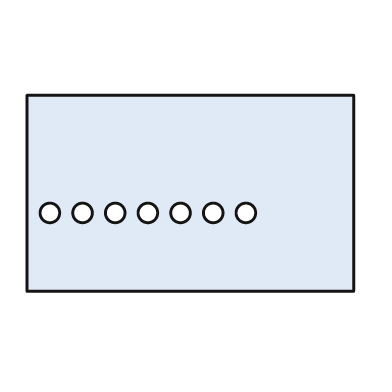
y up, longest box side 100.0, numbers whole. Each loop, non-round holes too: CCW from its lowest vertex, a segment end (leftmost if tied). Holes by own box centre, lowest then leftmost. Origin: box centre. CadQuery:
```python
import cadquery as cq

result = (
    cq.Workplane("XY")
    .moveTo(-50.0, -30.0)
    .lineTo(50.0, -30.0)
    .lineTo(50.0, 30.0)
    .lineTo(-50.0, 30.0)
    .close()
    .moveTo(-43.0, -6.0)
    .circle(3.0)
    .moveTo(-33.0, -6.0)
    .circle(3.0)
    .moveTo(-23.0, -6.0)
    .circle(3.0)
    .moveTo(-13.0, -6.0)
    .circle(3.0)
    .moveTo(-3.0, -6.0)
    .circle(3.0)
    .moveTo(7.0, -6.0)
    .circle(3.0)
    .moveTo(17.0, -6.0)
    .circle(3.0)
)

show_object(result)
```